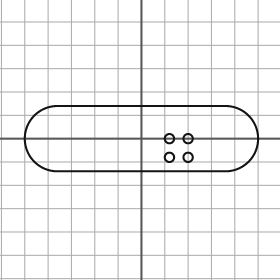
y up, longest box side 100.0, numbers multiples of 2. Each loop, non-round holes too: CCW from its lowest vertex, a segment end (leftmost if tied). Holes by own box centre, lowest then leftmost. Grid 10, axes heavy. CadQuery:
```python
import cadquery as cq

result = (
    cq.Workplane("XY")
    .moveTo(-36.0, -14.0)
    .lineTo(36.0, -14.0)
    .threePointArc((50.0, 0.0), (36.0, 14.0))
    .lineTo(-36.0, 14.0)
    .threePointArc((-50.0, 0.0), (-36.0, -14.0))
    .close()
    .moveTo(12.0, -8.0)
    .circle(2.0)
    .moveTo(20.0, -8.0)
    .circle(2.0)
    .moveTo(12.0, 0.0)
    .circle(2.0)
    .moveTo(20.0, 0.0)
    .circle(2.0)
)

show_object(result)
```